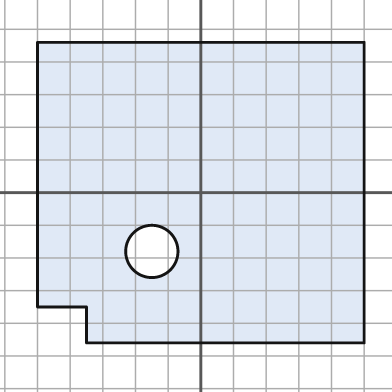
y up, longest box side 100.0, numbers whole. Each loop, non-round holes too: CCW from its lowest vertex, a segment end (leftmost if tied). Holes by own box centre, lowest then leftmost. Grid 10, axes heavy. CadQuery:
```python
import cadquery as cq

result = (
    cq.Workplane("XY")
    .moveTo(-35.0, -46.0)
    .lineTo(50.0, -46.0)
    .lineTo(50.0, 46.0)
    .lineTo(-50.0, 46.0)
    .lineTo(-50.0, -35.0)
    .lineTo(-35.0, -35.0)
    .close()
    .moveTo(-15.0, -18.0)
    .circle(8.0)
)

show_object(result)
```